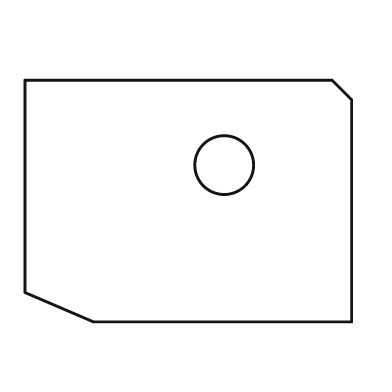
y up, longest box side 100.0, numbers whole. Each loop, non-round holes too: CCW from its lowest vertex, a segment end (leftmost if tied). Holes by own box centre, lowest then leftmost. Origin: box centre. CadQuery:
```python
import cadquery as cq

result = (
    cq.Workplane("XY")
    .moveTo(-29.0, -37.0)
    .lineTo(50.0, -37.0)
    .lineTo(50.0, 31.0)
    .lineTo(44.0, 37.0)
    .lineTo(-50.0, 37.0)
    .lineTo(-50.0, -28.0)
    .close()
    .moveTo(11.0, 11.0)
    .circle(9.0)
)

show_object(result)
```